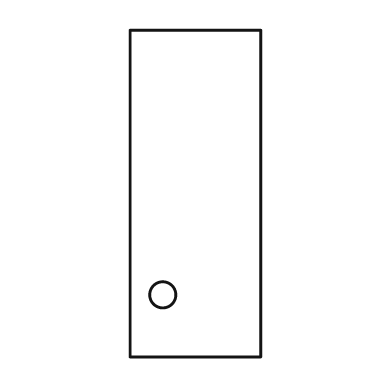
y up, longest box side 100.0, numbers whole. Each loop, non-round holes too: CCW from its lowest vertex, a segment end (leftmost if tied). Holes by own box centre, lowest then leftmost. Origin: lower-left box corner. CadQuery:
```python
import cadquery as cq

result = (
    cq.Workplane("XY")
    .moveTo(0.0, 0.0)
    .lineTo(40.0, 0.0)
    .lineTo(40.0, 100.0)
    .lineTo(0.0, 100.0)
    .close()
    .moveTo(10.0, 19.0)
    .circle(4.0)
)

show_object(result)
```